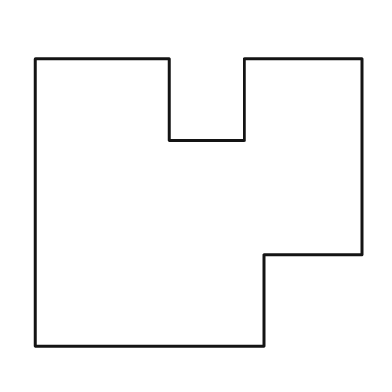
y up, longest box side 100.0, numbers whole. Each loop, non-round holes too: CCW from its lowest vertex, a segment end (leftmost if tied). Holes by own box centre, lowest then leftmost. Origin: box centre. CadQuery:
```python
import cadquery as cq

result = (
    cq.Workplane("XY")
    .moveTo(-50.0, -44.0)
    .lineTo(20.0, -44.0)
    .lineTo(20.0, -16.0)
    .lineTo(50.0, -16.0)
    .lineTo(50.0, 44.0)
    .lineTo(14.0, 44.0)
    .lineTo(14.0, 19.0)
    .lineTo(-9.0, 19.0)
    .lineTo(-9.0, 44.0)
    .lineTo(-50.0, 44.0)
    .close()
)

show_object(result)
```